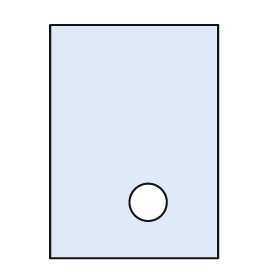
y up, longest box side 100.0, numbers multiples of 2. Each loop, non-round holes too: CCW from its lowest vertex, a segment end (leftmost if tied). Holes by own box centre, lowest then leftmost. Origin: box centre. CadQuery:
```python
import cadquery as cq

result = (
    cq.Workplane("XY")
    .moveTo(-36.0, -50.0)
    .lineTo(36.0, -50.0)
    .lineTo(36.0, 50.0)
    .lineTo(-36.0, 50.0)
    .close()
    .moveTo(6.0, -26.0)
    .circle(8.0)
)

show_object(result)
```